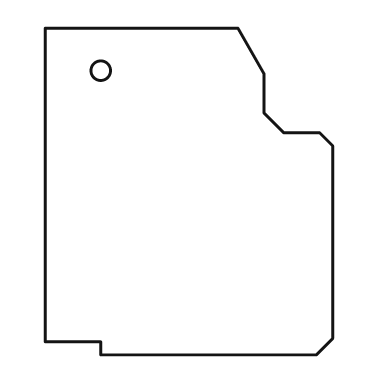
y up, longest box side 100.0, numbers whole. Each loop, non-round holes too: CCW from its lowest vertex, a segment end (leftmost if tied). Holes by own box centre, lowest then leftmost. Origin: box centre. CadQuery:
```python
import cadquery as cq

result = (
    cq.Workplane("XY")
    .moveTo(-27.0, -50.0)
    .lineTo(39.0, -50.0)
    .lineTo(44.0, -45.0)
    .lineTo(44.0, 14.0)
    .lineTo(40.0, 18.0)
    .lineTo(29.0, 18.0)
    .lineTo(23.0, 24.0)
    .lineTo(23.0, 36.0)
    .lineTo(15.0, 50.0)
    .lineTo(-44.0, 50.0)
    .lineTo(-44.0, -46.0)
    .lineTo(-27.0, -46.0)
    .close()
    .moveTo(-27.0, 37.0)
    .circle(3.0)
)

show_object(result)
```